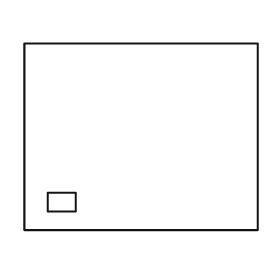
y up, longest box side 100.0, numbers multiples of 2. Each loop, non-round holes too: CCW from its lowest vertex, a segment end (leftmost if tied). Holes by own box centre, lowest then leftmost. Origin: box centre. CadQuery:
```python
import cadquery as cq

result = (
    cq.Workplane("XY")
    .moveTo(-50.0, -40.0)
    .lineTo(50.0, -40.0)
    .lineTo(50.0, 40.0)
    .lineTo(-50.0, 40.0)
    .close()
    .moveTo(-40.0, -32.0)
    .lineTo(-28.0, -32.0)
    .lineTo(-28.0, -24.0)
    .lineTo(-40.0, -24.0)
    .close()
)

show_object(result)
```